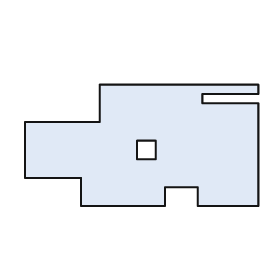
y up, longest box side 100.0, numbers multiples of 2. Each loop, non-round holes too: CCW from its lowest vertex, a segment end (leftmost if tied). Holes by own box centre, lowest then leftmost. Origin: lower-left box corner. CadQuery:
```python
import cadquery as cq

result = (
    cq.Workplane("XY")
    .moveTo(24.0, 0.0)
    .lineTo(60.0, 0.0)
    .lineTo(60.0, 8.0)
    .lineTo(74.0, 8.0)
    .lineTo(74.0, 0.0)
    .lineTo(100.0, 0.0)
    .lineTo(100.0, 44.0)
    .lineTo(76.0, 44.0)
    .lineTo(76.0, 48.0)
    .lineTo(100.0, 48.0)
    .lineTo(100.0, 52.0)
    .lineTo(32.0, 52.0)
    .lineTo(32.0, 36.0)
    .lineTo(0.0, 36.0)
    .lineTo(0.0, 12.0)
    .lineTo(24.0, 12.0)
    .close()
    .moveTo(48.0, 20.0)
    .lineTo(56.0, 20.0)
    .lineTo(56.0, 28.0)
    .lineTo(48.0, 28.0)
    .close()
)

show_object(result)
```